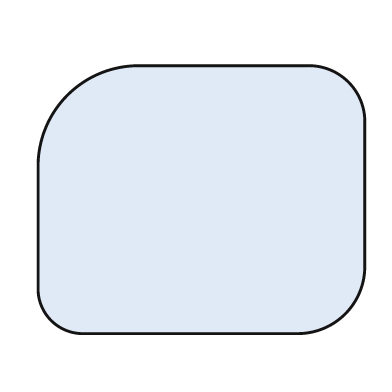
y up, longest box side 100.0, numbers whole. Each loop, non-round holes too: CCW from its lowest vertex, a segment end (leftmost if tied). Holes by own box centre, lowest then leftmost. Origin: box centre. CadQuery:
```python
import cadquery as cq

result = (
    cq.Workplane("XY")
    .moveTo(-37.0, -41.0)
    .lineTo(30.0, -41.0)
    .threePointArc((44.0, -35.0), (50.0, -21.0))
    .lineTo(50.0, 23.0)
    .threePointArc((45.0, 36.0), (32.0, 41.0))
    .lineTo(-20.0, 41.0)
    .threePointArc((-41.0, 32.0), (-50.0, 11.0))
    .lineTo(-50.0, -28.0)
    .threePointArc((-46.0, -37.0), (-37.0, -41.0))
    .close()
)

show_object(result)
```